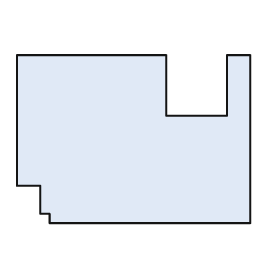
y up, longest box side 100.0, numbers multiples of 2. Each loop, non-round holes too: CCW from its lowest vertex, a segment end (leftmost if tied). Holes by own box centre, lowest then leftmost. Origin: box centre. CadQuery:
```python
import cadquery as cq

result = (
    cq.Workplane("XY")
    .moveTo(-36.0, -36.0)
    .lineTo(50.0, -36.0)
    .lineTo(50.0, 36.0)
    .lineTo(40.0, 36.0)
    .lineTo(40.0, 10.0)
    .lineTo(14.0, 10.0)
    .lineTo(14.0, 36.0)
    .lineTo(-50.0, 36.0)
    .lineTo(-50.0, -20.0)
    .lineTo(-40.0, -20.0)
    .lineTo(-40.0, -32.0)
    .lineTo(-36.0, -32.0)
    .close()
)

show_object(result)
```